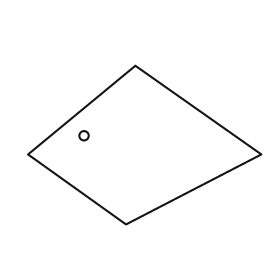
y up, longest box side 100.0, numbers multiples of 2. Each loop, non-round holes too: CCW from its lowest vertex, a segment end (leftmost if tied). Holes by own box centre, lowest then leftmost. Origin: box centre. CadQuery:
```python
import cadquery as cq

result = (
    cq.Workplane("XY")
    .moveTo(-8.0, -34.0)
    .lineTo(50.0, -4.0)
    .lineTo(-4.0, 34.0)
    .lineTo(-50.0, -4.0)
    .close()
    .moveTo(-26.0, 4.0)
    .circle(2.0)
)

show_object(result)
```